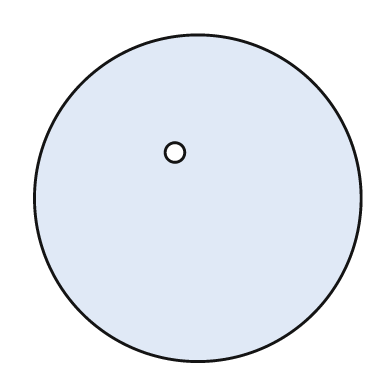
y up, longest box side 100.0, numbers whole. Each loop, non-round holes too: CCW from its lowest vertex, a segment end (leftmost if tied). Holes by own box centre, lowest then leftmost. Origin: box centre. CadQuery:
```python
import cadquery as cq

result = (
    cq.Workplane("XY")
    .moveTo(0.0, 0.0)
    .circle(50.0)
    .moveTo(-7.0, 14.0)
    .circle(3.0)
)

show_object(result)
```